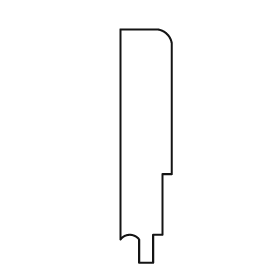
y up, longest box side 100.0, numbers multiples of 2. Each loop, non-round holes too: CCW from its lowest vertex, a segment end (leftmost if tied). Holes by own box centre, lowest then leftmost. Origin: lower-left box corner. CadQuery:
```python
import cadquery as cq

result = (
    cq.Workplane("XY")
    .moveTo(8.0, 0.0)
    .lineTo(14.0, 0.0)
    .lineTo(14.0, 12.0)
    .lineTo(18.0, 12.0)
    .lineTo(18.0, 38.0)
    .lineTo(22.0, 38.0)
    .lineTo(22.0, 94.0)
    .threePointArc((20.0, 98.0), (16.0, 100.0))
    .lineTo(0.0, 100.0)
    .lineTo(0.0, 10.0)
    .threePointArc((4.0, 12.0), (8.0, 10.0))
    .close()
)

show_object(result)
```